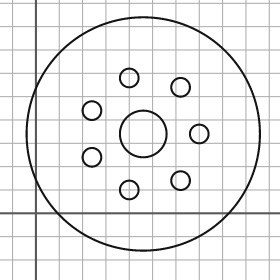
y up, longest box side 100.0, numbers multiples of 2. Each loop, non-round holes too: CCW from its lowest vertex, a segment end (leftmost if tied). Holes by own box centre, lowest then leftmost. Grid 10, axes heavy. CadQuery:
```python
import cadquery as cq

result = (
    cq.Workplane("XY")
    .moveTo(46.0, 34.0)
    .circle(50.0)
    .moveTo(40.0, 10.0)
    .circle(4.0)
    .moveTo(62.0, 14.0)
    .circle(4.0)
    .moveTo(24.0, 24.0)
    .circle(4.0)
    .moveTo(46.0, 34.0)
    .circle(10.0)
    .moveTo(70.0, 34.0)
    .circle(4.0)
    .moveTo(24.0, 44.0)
    .circle(4.0)
    .moveTo(62.0, 54.0)
    .circle(4.0)
    .moveTo(40.0, 58.0)
    .circle(4.0)
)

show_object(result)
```